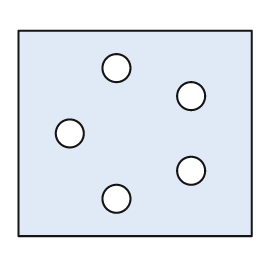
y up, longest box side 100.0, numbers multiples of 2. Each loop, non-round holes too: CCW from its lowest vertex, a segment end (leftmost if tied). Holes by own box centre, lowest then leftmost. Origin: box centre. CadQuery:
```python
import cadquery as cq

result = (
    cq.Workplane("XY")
    .moveTo(-50.0, -44.0)
    .lineTo(50.0, -44.0)
    .lineTo(50.0, 44.0)
    .lineTo(-50.0, 44.0)
    .close()
    .moveTo(-8.0, -28.0)
    .circle(6.0)
    .moveTo(24.0, -16.0)
    .circle(6.0)
    .moveTo(-28.0, 0.0)
    .circle(6.0)
    .moveTo(24.0, 16.0)
    .circle(6.0)
    .moveTo(-8.0, 28.0)
    .circle(6.0)
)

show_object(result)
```